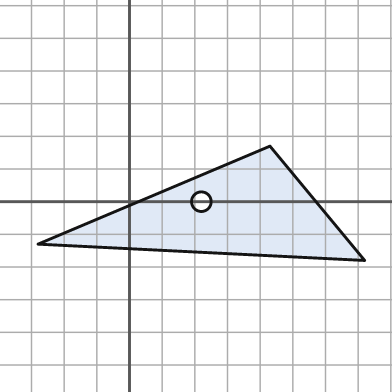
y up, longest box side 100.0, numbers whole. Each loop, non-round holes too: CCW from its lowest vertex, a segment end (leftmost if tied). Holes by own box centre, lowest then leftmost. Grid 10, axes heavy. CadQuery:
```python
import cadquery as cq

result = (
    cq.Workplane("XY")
    .moveTo(72.0, -18.0)
    .lineTo(43.0, 17.0)
    .lineTo(-28.0, -13.0)
    .close()
    .moveTo(22.0, 0.0)
    .circle(3.0)
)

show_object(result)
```